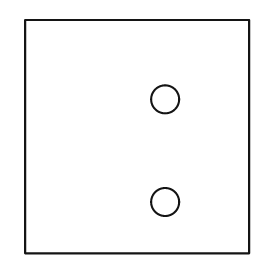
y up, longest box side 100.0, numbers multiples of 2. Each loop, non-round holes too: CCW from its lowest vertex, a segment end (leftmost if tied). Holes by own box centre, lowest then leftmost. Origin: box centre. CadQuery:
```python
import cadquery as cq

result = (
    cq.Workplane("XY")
    .moveTo(-48.0, -50.0)
    .lineTo(48.0, -50.0)
    .lineTo(48.0, 50.0)
    .lineTo(-48.0, 50.0)
    .close()
    .moveTo(12.0, -28.0)
    .circle(6.0)
    .moveTo(12.0, 16.0)
    .circle(6.0)
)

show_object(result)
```